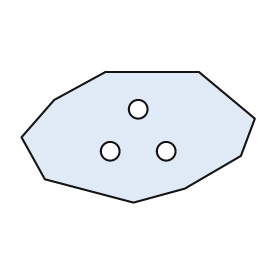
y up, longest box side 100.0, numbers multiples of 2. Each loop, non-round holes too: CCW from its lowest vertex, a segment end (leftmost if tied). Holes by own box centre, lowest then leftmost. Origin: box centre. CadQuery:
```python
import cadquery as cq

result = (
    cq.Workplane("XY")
    .moveTo(-2.0, -28.0)
    .lineTo(20.0, -22.0)
    .lineTo(44.0, -8.0)
    .lineTo(50.0, 8.0)
    .lineTo(26.0, 28.0)
    .lineTo(-14.0, 28.0)
    .lineTo(-36.0, 16.0)
    .lineTo(-50.0, 0.0)
    .lineTo(-40.0, -18.0)
    .close()
    .moveTo(-12.0, -6.0)
    .circle(4.0)
    .moveTo(12.0, -6.0)
    .circle(4.0)
    .moveTo(0.0, 12.0)
    .circle(4.0)
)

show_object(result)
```